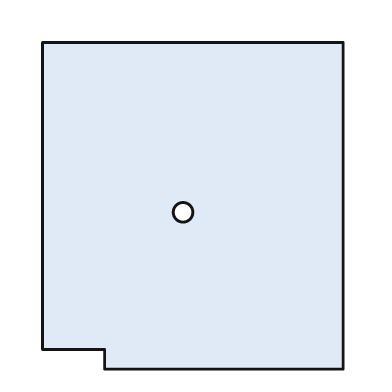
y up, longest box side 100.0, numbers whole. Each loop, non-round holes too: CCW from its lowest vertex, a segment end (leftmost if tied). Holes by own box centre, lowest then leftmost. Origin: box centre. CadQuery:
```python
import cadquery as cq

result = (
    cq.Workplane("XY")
    .moveTo(-27.0, -50.0)
    .lineTo(46.0, -50.0)
    .lineTo(46.0, 50.0)
    .lineTo(-46.0, 50.0)
    .lineTo(-46.0, -44.0)
    .lineTo(-27.0, -44.0)
    .close()
    .moveTo(-3.0, -2.0)
    .circle(3.0)
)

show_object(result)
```